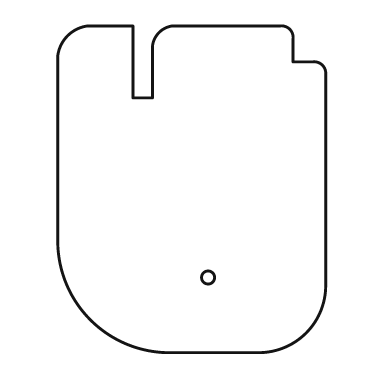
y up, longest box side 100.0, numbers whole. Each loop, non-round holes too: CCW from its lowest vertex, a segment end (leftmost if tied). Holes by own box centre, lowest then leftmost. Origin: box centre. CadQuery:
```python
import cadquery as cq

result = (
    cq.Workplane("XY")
    .moveTo(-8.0, -50.0)
    .lineTo(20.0, -50.0)
    .threePointArc((35.0, -44.0), (41.0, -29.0))
    .lineTo(41.0, 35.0)
    .threePointArc((40.0, 38.0), (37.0, 39.0))
    .lineTo(31.0, 39.0)
    .lineTo(31.0, 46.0)
    .threePointArc((30.0, 49.0), (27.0, 50.0))
    .lineTo(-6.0, 50.0)
    .threePointArc((-10.0, 48.0), (-12.0, 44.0))
    .lineTo(-12.0, 28.0)
    .lineTo(-18.0, 28.0)
    .lineTo(-18.0, 50.0)
    .lineTo(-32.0, 50.0)
    .threePointArc((-38.0, 47.0), (-41.0, 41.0))
    .lineTo(-41.0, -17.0)
    .threePointArc((-31.0, -40.0), (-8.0, -50.0))
    .close()
    .moveTo(5.0, -27.0)
    .circle(2.0)
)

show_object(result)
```